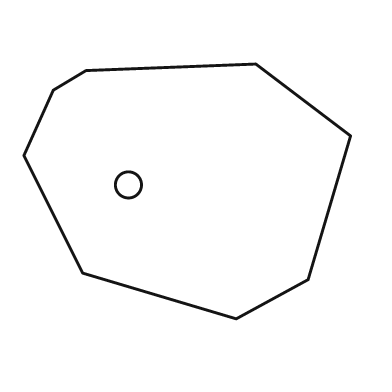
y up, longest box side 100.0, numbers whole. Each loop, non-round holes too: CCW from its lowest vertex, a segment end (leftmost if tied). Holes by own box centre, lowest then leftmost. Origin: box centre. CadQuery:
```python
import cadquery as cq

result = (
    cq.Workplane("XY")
    .moveTo(15.0, -39.0)
    .lineTo(37.0, -27.0)
    .lineTo(50.0, 17.0)
    .lineTo(21.0, 39.0)
    .lineTo(-31.0, 37.0)
    .lineTo(-41.0, 31.0)
    .lineTo(-50.0, 11.0)
    .lineTo(-32.0, -25.0)
    .close()
    .moveTo(-18.0, 2.0)
    .circle(4.0)
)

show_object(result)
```